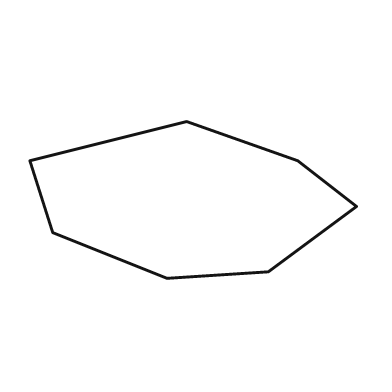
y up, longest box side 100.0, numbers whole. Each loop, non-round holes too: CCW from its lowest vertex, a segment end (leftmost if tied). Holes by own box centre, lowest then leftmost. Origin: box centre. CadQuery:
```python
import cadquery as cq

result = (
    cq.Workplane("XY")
    .moveTo(-8.0, -24.0)
    .lineTo(23.0, -22.0)
    .lineTo(50.0, -2.0)
    .lineTo(32.0, 12.0)
    .lineTo(-2.0, 24.0)
    .lineTo(-50.0, 12.0)
    .lineTo(-43.0, -10.0)
    .close()
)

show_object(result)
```